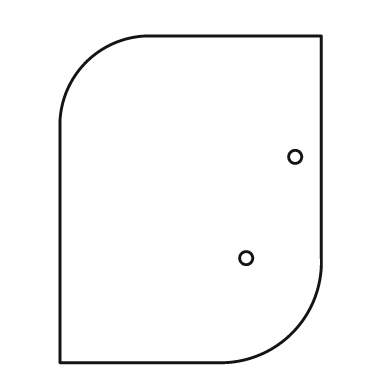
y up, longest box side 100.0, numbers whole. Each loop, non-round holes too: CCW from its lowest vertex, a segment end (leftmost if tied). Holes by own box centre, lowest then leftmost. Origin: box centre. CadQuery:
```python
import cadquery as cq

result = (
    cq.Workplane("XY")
    .moveTo(-40.0, -50.0)
    .lineTo(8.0, -50.0)
    .threePointArc((31.0, -41.0), (40.0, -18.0))
    .lineTo(40.0, 50.0)
    .lineTo(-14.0, 50.0)
    .threePointArc((-32.0, 42.0), (-40.0, 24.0))
    .close()
    .moveTo(17.0, -18.0)
    .circle(2.0)
    .moveTo(32.0, 13.0)
    .circle(2.0)
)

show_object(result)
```